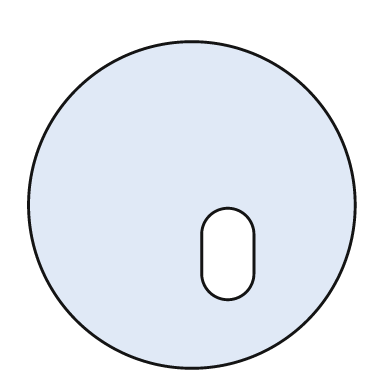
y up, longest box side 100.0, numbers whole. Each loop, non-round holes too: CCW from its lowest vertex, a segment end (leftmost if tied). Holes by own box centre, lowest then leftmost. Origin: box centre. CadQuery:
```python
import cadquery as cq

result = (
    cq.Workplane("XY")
    .moveTo(0.0, 0.0)
    .circle(50.0)
    .moveTo(3.0, -21.0)
    .threePointArc((11.0, -29.0), (19.0, -21.0))
    .lineTo(19.0, -9.0)
    .threePointArc((11.0, -1.0), (3.0, -9.0))
    .close()
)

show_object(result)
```